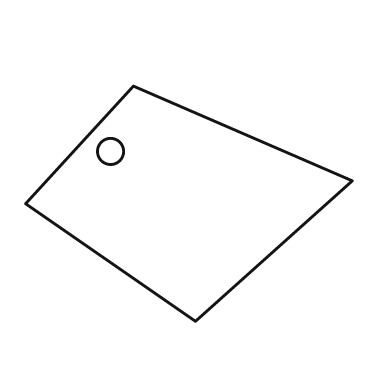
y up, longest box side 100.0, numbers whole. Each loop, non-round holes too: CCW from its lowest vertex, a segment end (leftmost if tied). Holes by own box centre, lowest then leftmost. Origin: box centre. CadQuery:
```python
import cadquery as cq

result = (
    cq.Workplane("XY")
    .moveTo(2.0, -36.0)
    .lineTo(50.0, 7.0)
    .lineTo(-17.0, 36.0)
    .lineTo(-50.0, 0.0)
    .close()
    .moveTo(-24.0, 16.0)
    .circle(4.0)
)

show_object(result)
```